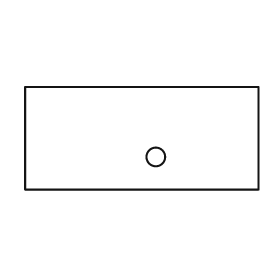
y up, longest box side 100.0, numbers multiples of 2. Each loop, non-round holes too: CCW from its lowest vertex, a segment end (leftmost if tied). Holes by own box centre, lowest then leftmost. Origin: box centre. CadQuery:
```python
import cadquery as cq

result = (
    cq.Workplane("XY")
    .moveTo(-50.0, -22.0)
    .lineTo(50.0, -22.0)
    .lineTo(50.0, 22.0)
    .lineTo(-50.0, 22.0)
    .close()
    .moveTo(6.0, -8.0)
    .circle(4.0)
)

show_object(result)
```